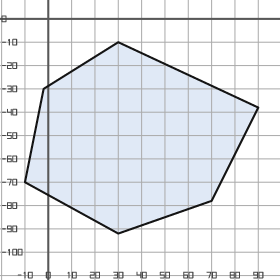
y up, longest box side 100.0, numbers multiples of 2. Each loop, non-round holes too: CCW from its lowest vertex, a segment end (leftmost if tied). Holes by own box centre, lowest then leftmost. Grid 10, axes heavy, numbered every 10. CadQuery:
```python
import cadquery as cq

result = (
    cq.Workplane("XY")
    .moveTo(30.0, -92.0)
    .lineTo(70.0, -78.0)
    .lineTo(90.0, -38.0)
    .lineTo(30.0, -10.0)
    .lineTo(-2.0, -30.0)
    .lineTo(-10.0, -70.0)
    .close()
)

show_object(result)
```